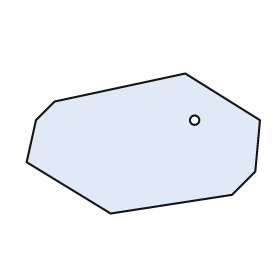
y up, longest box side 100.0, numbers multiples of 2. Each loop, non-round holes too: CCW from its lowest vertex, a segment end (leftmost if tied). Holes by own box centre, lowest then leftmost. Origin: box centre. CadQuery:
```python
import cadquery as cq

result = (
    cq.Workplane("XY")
    .moveTo(-14.0, -30.0)
    .lineTo(38.0, -22.0)
    .lineTo(48.0, -12.0)
    .lineTo(50.0, 10.0)
    .lineTo(18.0, 30.0)
    .lineTo(-38.0, 18.0)
    .lineTo(-46.0, 10.0)
    .lineTo(-50.0, -8.0)
    .close()
    .moveTo(22.0, 10.0)
    .circle(2.0)
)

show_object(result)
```